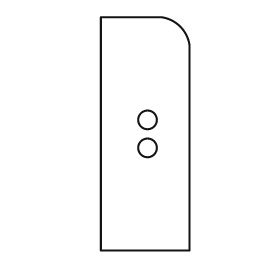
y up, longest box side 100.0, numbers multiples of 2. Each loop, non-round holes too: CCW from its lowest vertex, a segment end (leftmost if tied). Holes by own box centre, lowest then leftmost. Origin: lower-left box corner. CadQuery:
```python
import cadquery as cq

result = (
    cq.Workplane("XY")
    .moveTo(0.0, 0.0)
    .lineTo(38.0, 0.0)
    .lineTo(38.0, 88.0)
    .threePointArc((34.0, 96.0), (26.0, 100.0))
    .lineTo(0.0, 100.0)
    .close()
    .moveTo(20.0, 44.0)
    .circle(4.0)
    .moveTo(20.0, 56.0)
    .circle(4.0)
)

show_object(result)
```